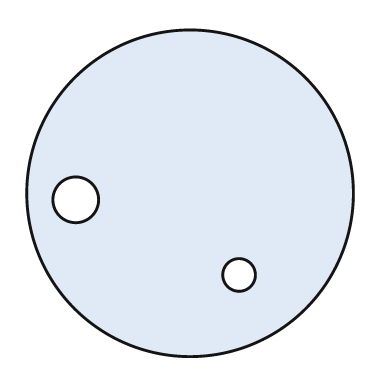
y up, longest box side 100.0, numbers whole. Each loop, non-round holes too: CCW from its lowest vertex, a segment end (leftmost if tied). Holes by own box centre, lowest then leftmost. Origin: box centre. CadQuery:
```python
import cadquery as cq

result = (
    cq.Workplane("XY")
    .moveTo(0.0, 0.0)
    .circle(50.0)
    .moveTo(15.0, -25.0)
    .circle(5.0)
    .moveTo(-35.0, -2.0)
    .circle(7.0)
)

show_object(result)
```